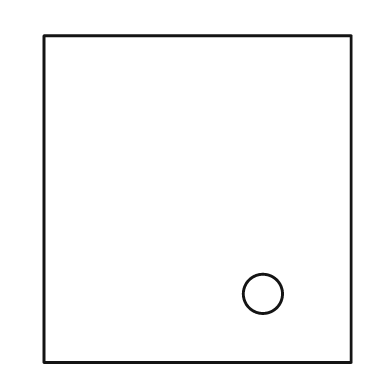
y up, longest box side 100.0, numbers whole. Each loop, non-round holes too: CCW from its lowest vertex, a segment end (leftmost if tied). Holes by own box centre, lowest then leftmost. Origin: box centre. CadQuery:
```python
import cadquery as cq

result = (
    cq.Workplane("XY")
    .moveTo(-47.0, -50.0)
    .lineTo(47.0, -50.0)
    .lineTo(47.0, 50.0)
    .lineTo(-47.0, 50.0)
    .close()
    .moveTo(20.0, -29.0)
    .circle(6.0)
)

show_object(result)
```